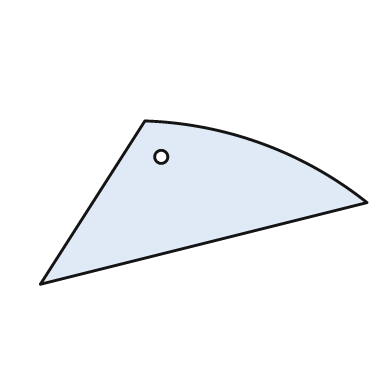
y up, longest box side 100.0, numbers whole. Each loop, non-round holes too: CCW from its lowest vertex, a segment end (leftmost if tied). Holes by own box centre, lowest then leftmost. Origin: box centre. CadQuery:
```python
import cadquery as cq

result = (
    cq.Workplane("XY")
    .moveTo(-50.0, -25.0)
    .lineTo(50.0, 0.0)
    .threePointArc((18.0, 18.0), (-18.0, 25.0))
    .close()
    .moveTo(-13.0, 14.0)
    .circle(2.0)
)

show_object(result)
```